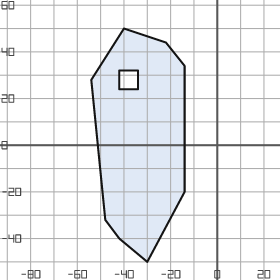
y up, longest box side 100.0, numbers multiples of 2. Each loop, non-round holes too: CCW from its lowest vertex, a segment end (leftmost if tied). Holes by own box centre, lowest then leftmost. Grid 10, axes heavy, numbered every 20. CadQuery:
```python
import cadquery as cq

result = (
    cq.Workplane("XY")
    .moveTo(-30.0, -50.0)
    .lineTo(-14.0, -20.0)
    .lineTo(-14.0, 34.0)
    .lineTo(-22.0, 44.0)
    .lineTo(-40.0, 50.0)
    .lineTo(-54.0, 28.0)
    .lineTo(-48.0, -32.0)
    .lineTo(-42.0, -40.0)
    .close()
    .moveTo(-42.0, 24.0)
    .lineTo(-34.0, 24.0)
    .lineTo(-34.0, 32.0)
    .lineTo(-42.0, 32.0)
    .close()
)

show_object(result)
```